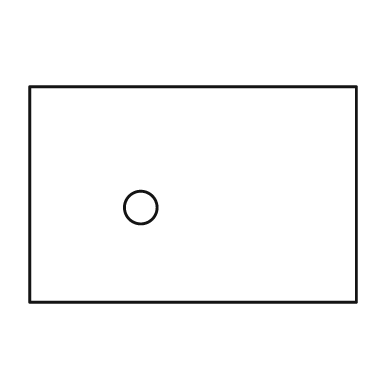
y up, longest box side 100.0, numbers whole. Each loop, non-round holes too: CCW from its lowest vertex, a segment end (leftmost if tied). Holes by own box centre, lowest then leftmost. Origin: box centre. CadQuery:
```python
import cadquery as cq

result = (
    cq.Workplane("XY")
    .moveTo(-50.0, -33.0)
    .lineTo(50.0, -33.0)
    .lineTo(50.0, 33.0)
    .lineTo(-50.0, 33.0)
    .close()
    .moveTo(-16.0, -4.0)
    .circle(5.0)
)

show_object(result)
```